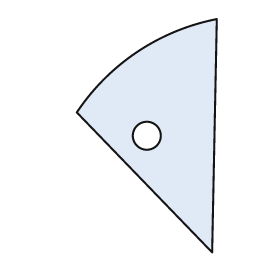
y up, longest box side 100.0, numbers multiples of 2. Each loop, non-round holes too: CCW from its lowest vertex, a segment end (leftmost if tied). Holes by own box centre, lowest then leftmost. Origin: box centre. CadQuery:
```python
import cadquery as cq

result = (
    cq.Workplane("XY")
    .moveTo(28.0, -50.0)
    .lineTo(30.0, 50.0)
    .threePointArc((-4.0, 36.0), (-30.0, 10.0))
    .close()
    .moveTo(0.0, 0.0)
    .circle(6.0)
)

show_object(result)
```